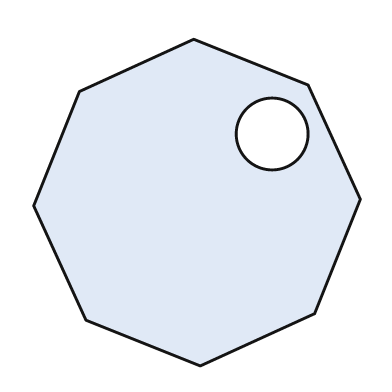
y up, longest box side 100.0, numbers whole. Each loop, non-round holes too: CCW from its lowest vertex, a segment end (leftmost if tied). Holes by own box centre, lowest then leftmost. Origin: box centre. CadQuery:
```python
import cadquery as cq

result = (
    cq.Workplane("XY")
    .moveTo(1.0, -50.0)
    .lineTo(36.0, -34.0)
    .lineTo(50.0, 1.0)
    .lineTo(34.0, 36.0)
    .lineTo(-1.0, 50.0)
    .lineTo(-36.0, 34.0)
    .lineTo(-50.0, -1.0)
    .lineTo(-34.0, -36.0)
    .close()
    .moveTo(23.0, 21.0)
    .circle(11.0)
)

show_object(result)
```